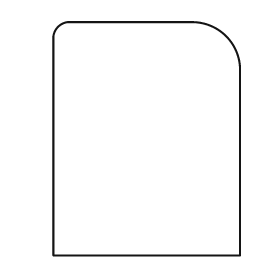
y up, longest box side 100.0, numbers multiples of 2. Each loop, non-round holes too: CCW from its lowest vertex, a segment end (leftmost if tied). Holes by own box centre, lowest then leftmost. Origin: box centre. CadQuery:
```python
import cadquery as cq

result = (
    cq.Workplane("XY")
    .moveTo(-40.0, -50.0)
    .lineTo(40.0, -50.0)
    .lineTo(40.0, 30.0)
    .threePointArc((34.0, 44.0), (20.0, 50.0))
    .lineTo(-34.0, 50.0)
    .threePointArc((-38.0, 48.0), (-40.0, 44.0))
    .close()
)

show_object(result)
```